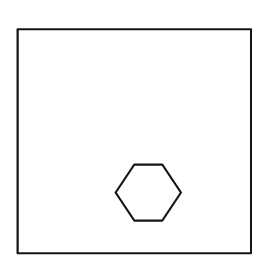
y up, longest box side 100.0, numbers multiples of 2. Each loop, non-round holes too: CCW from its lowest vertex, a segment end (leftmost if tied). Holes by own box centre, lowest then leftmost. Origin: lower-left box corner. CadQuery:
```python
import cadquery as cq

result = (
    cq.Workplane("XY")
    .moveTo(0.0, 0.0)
    .lineTo(100.0, 0.0)
    .lineTo(100.0, 96.0)
    .lineTo(0.0, 96.0)
    .close()
    .moveTo(50.0, 14.0)
    .lineTo(62.0, 14.0)
    .lineTo(70.0, 26.0)
    .lineTo(62.0, 38.0)
    .lineTo(50.0, 38.0)
    .lineTo(42.0, 26.0)
    .close()
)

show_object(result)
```